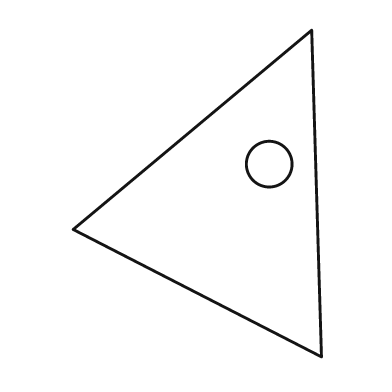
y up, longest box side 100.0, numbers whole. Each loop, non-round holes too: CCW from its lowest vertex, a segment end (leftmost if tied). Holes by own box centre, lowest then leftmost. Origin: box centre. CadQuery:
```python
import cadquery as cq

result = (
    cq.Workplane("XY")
    .moveTo(38.0, -50.0)
    .lineTo(35.0, 50.0)
    .lineTo(-38.0, -11.0)
    .close()
    .moveTo(22.0, 9.0)
    .circle(7.0)
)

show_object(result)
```